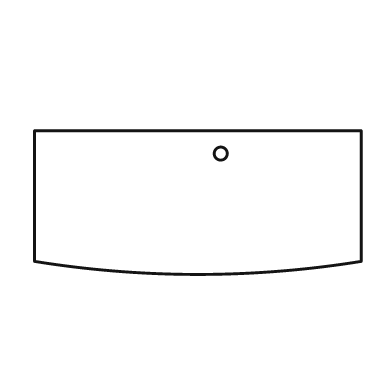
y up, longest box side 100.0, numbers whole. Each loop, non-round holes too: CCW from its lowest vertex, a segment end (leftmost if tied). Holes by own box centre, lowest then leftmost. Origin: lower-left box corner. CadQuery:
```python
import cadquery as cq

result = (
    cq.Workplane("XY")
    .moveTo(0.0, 4.0)
    .threePointArc((50.0, 0.0), (100.0, 4.0))
    .lineTo(100.0, 44.0)
    .lineTo(0.0, 44.0)
    .close()
    .moveTo(57.0, 37.0)
    .circle(2.0)
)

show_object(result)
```